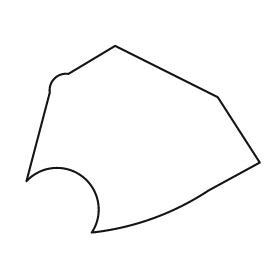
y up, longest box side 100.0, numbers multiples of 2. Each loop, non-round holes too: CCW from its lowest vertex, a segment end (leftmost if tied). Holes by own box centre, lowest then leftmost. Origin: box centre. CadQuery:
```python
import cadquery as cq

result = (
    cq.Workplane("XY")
    .moveTo(-22.0, -40.0)
    .threePointArc((4.0, -34.0), (28.0, -22.0))
    .lineTo(50.0, -10.0)
    .lineTo(32.0, 18.0)
    .lineTo(-12.0, 40.0)
    .lineTo(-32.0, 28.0)
    .threePointArc((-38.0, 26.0), (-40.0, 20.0))
    .lineTo(-50.0, -18.0)
    .threePointArc((-26.0, -16.0), (-22.0, -40.0))
    .close()
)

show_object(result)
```